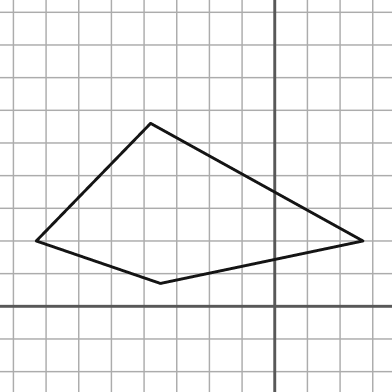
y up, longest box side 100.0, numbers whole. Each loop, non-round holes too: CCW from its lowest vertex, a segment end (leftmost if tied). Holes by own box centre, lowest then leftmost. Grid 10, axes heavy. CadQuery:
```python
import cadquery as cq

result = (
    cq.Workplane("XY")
    .moveTo(-35.0, 7.0)
    .lineTo(27.0, 20.0)
    .lineTo(-38.0, 56.0)
    .lineTo(-73.0, 20.0)
    .close()
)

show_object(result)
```